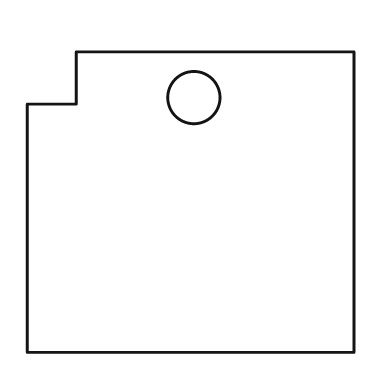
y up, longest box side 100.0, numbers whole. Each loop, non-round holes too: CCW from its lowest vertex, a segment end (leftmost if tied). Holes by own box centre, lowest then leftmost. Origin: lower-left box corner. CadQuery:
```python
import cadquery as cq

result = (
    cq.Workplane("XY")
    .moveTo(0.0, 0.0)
    .lineTo(100.0, 0.0)
    .lineTo(100.0, 92.0)
    .lineTo(15.0, 92.0)
    .lineTo(15.0, 76.0)
    .lineTo(0.0, 76.0)
    .close()
    .moveTo(51.0, 78.0)
    .circle(8.0)
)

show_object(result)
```